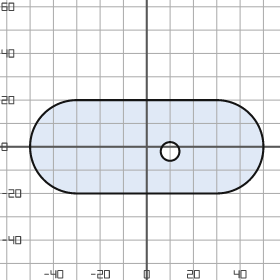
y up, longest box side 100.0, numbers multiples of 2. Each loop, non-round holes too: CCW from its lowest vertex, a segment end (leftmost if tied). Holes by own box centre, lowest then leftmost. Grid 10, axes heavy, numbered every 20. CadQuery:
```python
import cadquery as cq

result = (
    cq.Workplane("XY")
    .moveTo(-30.0, -20.0)
    .lineTo(30.0, -20.0)
    .threePointArc((50.0, 0.0), (30.0, 20.0))
    .lineTo(-30.0, 20.0)
    .threePointArc((-50.0, 0.0), (-30.0, -20.0))
    .close()
    .moveTo(10.0, -2.0)
    .circle(4.0)
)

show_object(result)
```